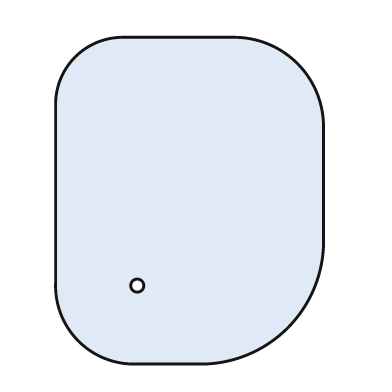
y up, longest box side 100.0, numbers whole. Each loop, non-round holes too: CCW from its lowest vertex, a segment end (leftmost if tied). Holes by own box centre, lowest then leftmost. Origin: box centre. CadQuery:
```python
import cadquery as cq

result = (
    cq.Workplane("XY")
    .moveTo(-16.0, -50.0)
    .lineTo(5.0, -50.0)
    .threePointArc((30.0, -39.0), (41.0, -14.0))
    .lineTo(41.0, 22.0)
    .threePointArc((33.0, 42.0), (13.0, 50.0))
    .lineTo(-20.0, 50.0)
    .threePointArc((-35.0, 44.0), (-41.0, 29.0))
    .lineTo(-41.0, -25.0)
    .threePointArc((-34.0, -43.0), (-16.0, -50.0))
    .close()
    .moveTo(-16.0, -26.0)
    .circle(2.0)
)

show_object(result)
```